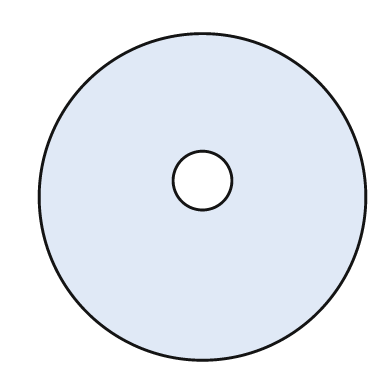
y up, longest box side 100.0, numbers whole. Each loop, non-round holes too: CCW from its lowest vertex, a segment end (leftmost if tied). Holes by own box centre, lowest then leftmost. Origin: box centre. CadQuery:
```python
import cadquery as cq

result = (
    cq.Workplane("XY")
    .moveTo(0.0, 0.0)
    .circle(50.0)
    .moveTo(0.0, 5.0)
    .circle(9.0)
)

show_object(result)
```